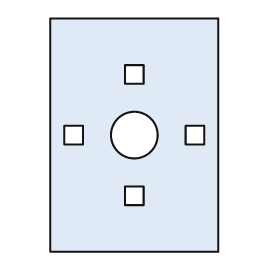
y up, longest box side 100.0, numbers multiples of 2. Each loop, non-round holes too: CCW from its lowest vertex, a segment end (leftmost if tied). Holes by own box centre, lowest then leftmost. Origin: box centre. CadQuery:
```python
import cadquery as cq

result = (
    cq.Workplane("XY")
    .moveTo(-36.0, -50.0)
    .lineTo(36.0, -50.0)
    .lineTo(36.0, 50.0)
    .lineTo(-36.0, 50.0)
    .close()
    .moveTo(-4.0, -30.0)
    .lineTo(4.0, -30.0)
    .lineTo(4.0, -22.0)
    .lineTo(-4.0, -22.0)
    .close()
    .moveTo(-30.0, -4.0)
    .lineTo(-22.0, -4.0)
    .lineTo(-22.0, 4.0)
    .lineTo(-30.0, 4.0)
    .close()
    .moveTo(0.0, 0.0)
    .circle(10.0)
    .moveTo(22.0, -4.0)
    .lineTo(30.0, -4.0)
    .lineTo(30.0, 4.0)
    .lineTo(22.0, 4.0)
    .close()
    .moveTo(-4.0, 22.0)
    .lineTo(4.0, 22.0)
    .lineTo(4.0, 30.0)
    .lineTo(-4.0, 30.0)
    .close()
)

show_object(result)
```